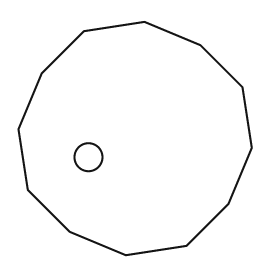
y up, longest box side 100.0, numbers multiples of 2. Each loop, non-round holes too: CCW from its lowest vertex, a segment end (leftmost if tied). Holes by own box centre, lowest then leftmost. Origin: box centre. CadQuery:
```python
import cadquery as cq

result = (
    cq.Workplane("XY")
    .moveTo(-4.0, -50.0)
    .lineTo(22.0, -46.0)
    .lineTo(40.0, -28.0)
    .lineTo(50.0, -4.0)
    .lineTo(46.0, 22.0)
    .lineTo(28.0, 40.0)
    .lineTo(4.0, 50.0)
    .lineTo(-22.0, 46.0)
    .lineTo(-40.0, 28.0)
    .lineTo(-50.0, 4.0)
    .lineTo(-46.0, -22.0)
    .lineTo(-28.0, -40.0)
    .close()
    .moveTo(-20.0, -8.0)
    .circle(6.0)
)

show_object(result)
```